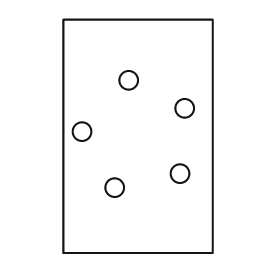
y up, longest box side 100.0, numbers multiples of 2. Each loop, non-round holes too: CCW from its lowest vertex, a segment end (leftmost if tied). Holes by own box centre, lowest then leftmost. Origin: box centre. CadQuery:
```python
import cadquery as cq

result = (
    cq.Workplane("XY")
    .moveTo(-32.0, -50.0)
    .lineTo(32.0, -50.0)
    .lineTo(32.0, 50.0)
    .lineTo(-32.0, 50.0)
    .close()
    .moveTo(-10.0, -22.0)
    .circle(4.0)
    .moveTo(18.0, -16.0)
    .circle(4.0)
    .moveTo(-24.0, 2.0)
    .circle(4.0)
    .moveTo(20.0, 12.0)
    .circle(4.0)
    .moveTo(-4.0, 24.0)
    .circle(4.0)
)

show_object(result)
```